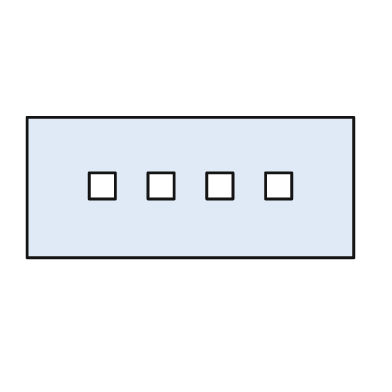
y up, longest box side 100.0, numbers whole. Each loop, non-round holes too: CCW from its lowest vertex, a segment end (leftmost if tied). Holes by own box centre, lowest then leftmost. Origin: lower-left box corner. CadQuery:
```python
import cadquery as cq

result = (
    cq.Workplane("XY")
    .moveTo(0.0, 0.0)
    .lineTo(100.0, 0.0)
    .lineTo(100.0, 43.0)
    .lineTo(0.0, 43.0)
    .close()
    .moveTo(19.0, 18.0)
    .lineTo(27.0, 18.0)
    .lineTo(27.0, 26.0)
    .lineTo(19.0, 26.0)
    .close()
    .moveTo(37.0, 18.0)
    .lineTo(45.0, 18.0)
    .lineTo(45.0, 26.0)
    .lineTo(37.0, 26.0)
    .close()
    .moveTo(55.0, 18.0)
    .lineTo(63.0, 18.0)
    .lineTo(63.0, 26.0)
    .lineTo(55.0, 26.0)
    .close()
    .moveTo(73.0, 18.0)
    .lineTo(81.0, 18.0)
    .lineTo(81.0, 26.0)
    .lineTo(73.0, 26.0)
    .close()
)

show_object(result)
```